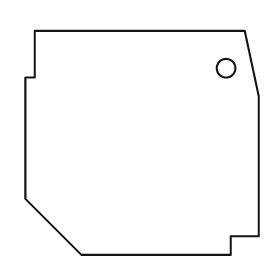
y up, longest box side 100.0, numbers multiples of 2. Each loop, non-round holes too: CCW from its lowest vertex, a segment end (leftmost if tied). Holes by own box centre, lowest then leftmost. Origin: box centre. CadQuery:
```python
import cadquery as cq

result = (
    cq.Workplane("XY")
    .moveTo(-26.0, -48.0)
    .lineTo(38.0, -48.0)
    .lineTo(38.0, -40.0)
    .lineTo(50.0, -40.0)
    .lineTo(50.0, 20.0)
    .lineTo(44.0, 48.0)
    .lineTo(-46.0, 48.0)
    .lineTo(-46.0, 28.0)
    .lineTo(-50.0, 28.0)
    .lineTo(-50.0, -24.0)
    .close()
    .moveTo(36.0, 32.0)
    .circle(4.0)
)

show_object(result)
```